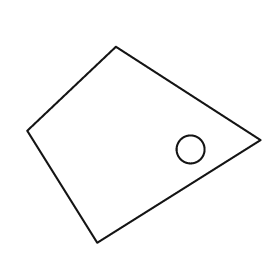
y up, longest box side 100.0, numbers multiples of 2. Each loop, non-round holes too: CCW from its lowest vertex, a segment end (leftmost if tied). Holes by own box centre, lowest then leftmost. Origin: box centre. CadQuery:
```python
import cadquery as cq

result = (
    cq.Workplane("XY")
    .moveTo(-20.0, -42.0)
    .lineTo(50.0, 2.0)
    .lineTo(-12.0, 42.0)
    .lineTo(-50.0, 6.0)
    .close()
    .moveTo(20.0, -2.0)
    .circle(6.0)
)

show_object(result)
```